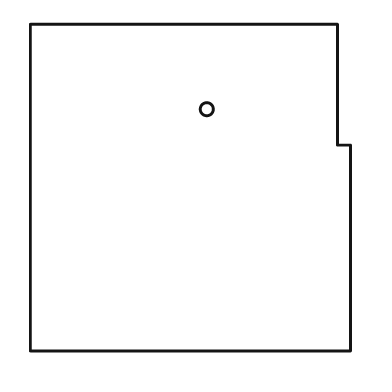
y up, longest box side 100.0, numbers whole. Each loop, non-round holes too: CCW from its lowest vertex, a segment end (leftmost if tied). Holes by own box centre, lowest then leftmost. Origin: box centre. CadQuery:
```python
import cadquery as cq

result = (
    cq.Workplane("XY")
    .moveTo(-49.0, -50.0)
    .lineTo(49.0, -50.0)
    .lineTo(49.0, 13.0)
    .lineTo(45.0, 13.0)
    .lineTo(45.0, 50.0)
    .lineTo(-49.0, 50.0)
    .close()
    .moveTo(5.0, 24.0)
    .circle(2.0)
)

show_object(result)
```